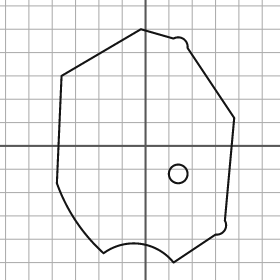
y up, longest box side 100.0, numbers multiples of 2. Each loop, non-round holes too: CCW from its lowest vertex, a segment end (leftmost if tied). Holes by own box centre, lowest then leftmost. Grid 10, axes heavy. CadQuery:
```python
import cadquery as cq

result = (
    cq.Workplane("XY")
    .moveTo(12.0, -50.0)
    .lineTo(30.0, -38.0)
    .threePointArc((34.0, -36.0), (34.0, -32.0))
    .lineTo(38.0, 12.0)
    .lineTo(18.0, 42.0)
    .threePointArc((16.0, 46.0), (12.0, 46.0))
    .lineTo(-2.0, 50.0)
    .lineTo(-36.0, 30.0)
    .lineTo(-38.0, -16.0)
    .threePointArc((-30.0, -32.0), (-18.0, -46.0))
    .threePointArc((-2.0, -42.0), (12.0, -50.0))
    .close()
    .moveTo(14.0, -12.0)
    .circle(4.0)
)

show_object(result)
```